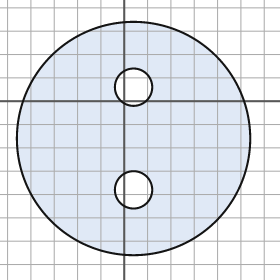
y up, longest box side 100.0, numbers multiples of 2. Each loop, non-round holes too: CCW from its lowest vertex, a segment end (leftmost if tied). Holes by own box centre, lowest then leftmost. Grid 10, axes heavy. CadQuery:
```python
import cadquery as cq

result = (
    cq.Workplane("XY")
    .moveTo(4.0, -16.0)
    .circle(50.0)
    .moveTo(4.0, -38.0)
    .circle(8.0)
    .moveTo(4.0, 6.0)
    .circle(8.0)
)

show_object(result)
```